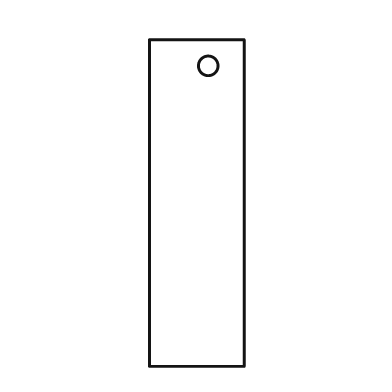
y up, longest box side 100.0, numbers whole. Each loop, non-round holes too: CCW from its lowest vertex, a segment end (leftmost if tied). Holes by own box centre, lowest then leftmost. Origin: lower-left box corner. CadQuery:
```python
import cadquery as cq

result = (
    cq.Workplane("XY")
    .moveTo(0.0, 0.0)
    .lineTo(29.0, 0.0)
    .lineTo(29.0, 100.0)
    .lineTo(0.0, 100.0)
    .close()
    .moveTo(18.0, 92.0)
    .circle(3.0)
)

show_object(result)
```